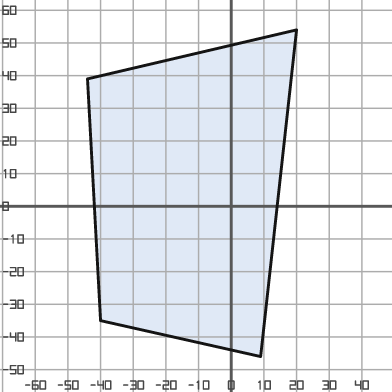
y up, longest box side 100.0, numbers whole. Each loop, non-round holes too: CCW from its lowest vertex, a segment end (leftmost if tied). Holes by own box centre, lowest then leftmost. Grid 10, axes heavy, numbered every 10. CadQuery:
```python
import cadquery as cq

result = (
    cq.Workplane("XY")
    .moveTo(9.0, -46.0)
    .lineTo(20.0, 54.0)
    .lineTo(-44.0, 39.0)
    .lineTo(-40.0, -35.0)
    .close()
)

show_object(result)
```